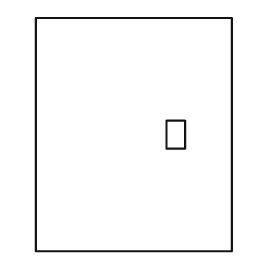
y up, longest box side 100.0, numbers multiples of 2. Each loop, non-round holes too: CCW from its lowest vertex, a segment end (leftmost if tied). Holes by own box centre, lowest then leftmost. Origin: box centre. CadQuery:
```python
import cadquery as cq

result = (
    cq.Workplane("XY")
    .moveTo(-42.0, -50.0)
    .lineTo(42.0, -50.0)
    .lineTo(42.0, 50.0)
    .lineTo(-42.0, 50.0)
    .close()
    .moveTo(14.0, -6.0)
    .lineTo(22.0, -6.0)
    .lineTo(22.0, 6.0)
    .lineTo(14.0, 6.0)
    .close()
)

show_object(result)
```